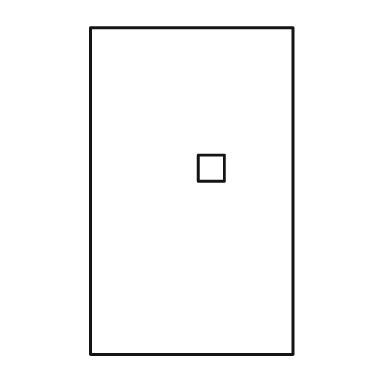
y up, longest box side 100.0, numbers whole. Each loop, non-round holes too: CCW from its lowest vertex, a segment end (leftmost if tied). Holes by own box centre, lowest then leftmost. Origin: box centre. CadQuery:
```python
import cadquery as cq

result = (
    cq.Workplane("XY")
    .moveTo(-31.0, -50.0)
    .lineTo(31.0, -50.0)
    .lineTo(31.0, 50.0)
    .lineTo(-31.0, 50.0)
    .close()
    .moveTo(2.0, 3.0)
    .lineTo(10.0, 3.0)
    .lineTo(10.0, 11.0)
    .lineTo(2.0, 11.0)
    .close()
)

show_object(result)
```